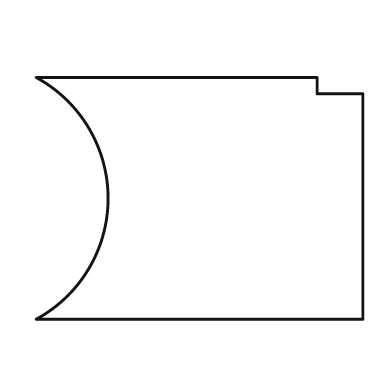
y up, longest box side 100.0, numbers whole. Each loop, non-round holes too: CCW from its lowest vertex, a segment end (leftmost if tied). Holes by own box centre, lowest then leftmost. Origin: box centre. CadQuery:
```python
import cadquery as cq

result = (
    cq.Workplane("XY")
    .moveTo(-50.0, -37.0)
    .lineTo(50.0, -37.0)
    .lineTo(50.0, 32.0)
    .lineTo(36.0, 32.0)
    .lineTo(36.0, 37.0)
    .lineTo(-50.0, 37.0)
    .threePointArc((-28.0, 0.0), (-50.0, -37.0))
    .close()
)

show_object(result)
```